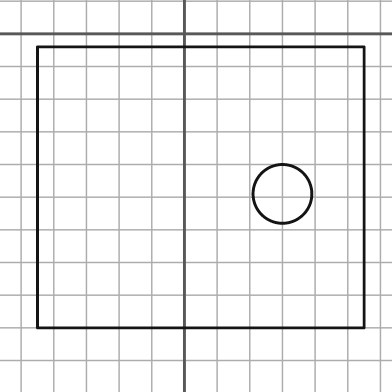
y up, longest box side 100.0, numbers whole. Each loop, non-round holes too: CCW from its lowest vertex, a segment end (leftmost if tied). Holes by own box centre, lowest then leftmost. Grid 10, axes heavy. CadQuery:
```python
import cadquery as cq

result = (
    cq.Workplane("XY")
    .moveTo(-45.0, -90.0)
    .lineTo(55.0, -90.0)
    .lineTo(55.0, -4.0)
    .lineTo(-45.0, -4.0)
    .close()
    .moveTo(30.0, -49.0)
    .circle(9.0)
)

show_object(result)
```